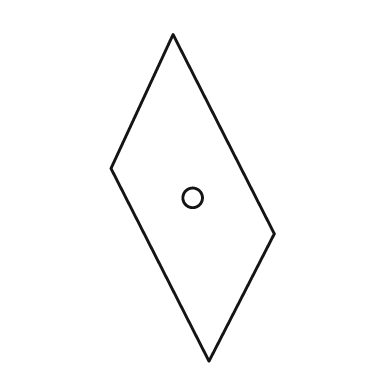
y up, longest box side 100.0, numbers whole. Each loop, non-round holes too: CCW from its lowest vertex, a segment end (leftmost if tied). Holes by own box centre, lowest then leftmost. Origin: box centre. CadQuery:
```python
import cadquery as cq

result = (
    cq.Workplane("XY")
    .moveTo(5.0, -50.0)
    .lineTo(25.0, -11.0)
    .lineTo(-6.0, 50.0)
    .lineTo(-25.0, 9.0)
    .close()
    .moveTo(0.0, 0.0)
    .circle(3.0)
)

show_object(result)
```